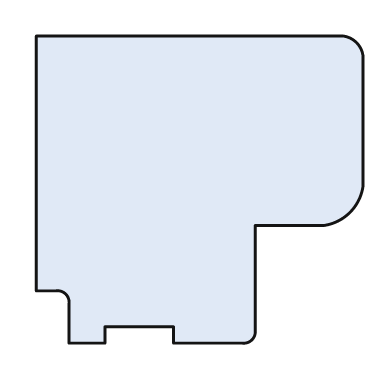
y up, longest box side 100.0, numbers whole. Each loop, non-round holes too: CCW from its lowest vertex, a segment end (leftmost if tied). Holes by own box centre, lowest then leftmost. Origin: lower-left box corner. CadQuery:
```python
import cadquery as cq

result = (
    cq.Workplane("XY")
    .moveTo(10.0, 0.0)
    .lineTo(21.0, 0.0)
    .lineTo(21.0, 5.0)
    .lineTo(42.0, 5.0)
    .lineTo(42.0, 0.0)
    .lineTo(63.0, 0.0)
    .threePointArc((66.0, 1.0), (67.0, 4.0))
    .lineTo(67.0, 36.0)
    .lineTo(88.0, 36.0)
    .threePointArc((96.0, 40.0), (100.0, 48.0))
    .lineTo(100.0, 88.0)
    .threePointArc((98.0, 92.0), (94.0, 94.0))
    .lineTo(0.0, 94.0)
    .lineTo(0.0, 16.0)
    .lineTo(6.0, 16.0)
    .threePointArc((9.0, 15.0), (10.0, 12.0))
    .close()
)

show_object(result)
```